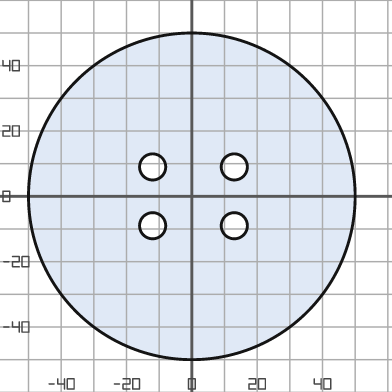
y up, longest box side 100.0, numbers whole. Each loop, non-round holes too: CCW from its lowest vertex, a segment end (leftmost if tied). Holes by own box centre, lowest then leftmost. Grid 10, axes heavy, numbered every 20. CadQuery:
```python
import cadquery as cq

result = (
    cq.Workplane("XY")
    .moveTo(0.0, 0.0)
    .circle(50.0)
    .moveTo(-12.0, -9.0)
    .circle(4.0)
    .moveTo(13.0, -9.0)
    .circle(4.0)
    .moveTo(-12.0, 9.0)
    .circle(4.0)
    .moveTo(13.0, 9.0)
    .circle(4.0)
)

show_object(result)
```